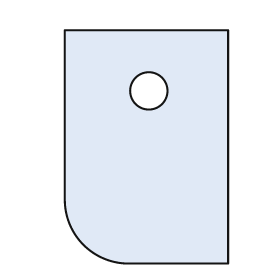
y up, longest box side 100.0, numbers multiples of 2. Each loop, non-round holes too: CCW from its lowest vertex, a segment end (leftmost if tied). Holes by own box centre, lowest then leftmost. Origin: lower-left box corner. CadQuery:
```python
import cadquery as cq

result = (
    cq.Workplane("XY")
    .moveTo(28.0, 0.0)
    .lineTo(70.0, 0.0)
    .lineTo(70.0, 100.0)
    .lineTo(0.0, 100.0)
    .lineTo(0.0, 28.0)
    .threePointArc((8.0, 8.0), (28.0, 0.0))
    .close()
    .moveTo(36.0, 74.0)
    .circle(8.0)
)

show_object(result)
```